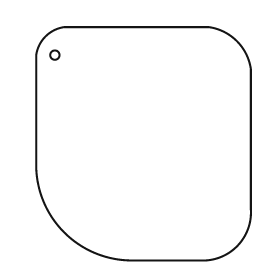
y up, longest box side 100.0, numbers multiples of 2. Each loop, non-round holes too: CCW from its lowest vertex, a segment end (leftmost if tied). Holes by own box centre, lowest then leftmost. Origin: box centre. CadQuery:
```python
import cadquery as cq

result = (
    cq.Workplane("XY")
    .moveTo(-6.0, -50.0)
    .lineTo(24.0, -50.0)
    .threePointArc((40.0, -44.0), (46.0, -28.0))
    .lineTo(46.0, 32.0)
    .threePointArc((40.0, 44.0), (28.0, 50.0))
    .lineTo(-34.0, 50.0)
    .threePointArc((-42.0, 46.0), (-46.0, 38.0))
    .lineTo(-46.0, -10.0)
    .threePointArc((-34.0, -38.0), (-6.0, -50.0))
    .close()
    .moveTo(-38.0, 38.0)
    .circle(2.0)
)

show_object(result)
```